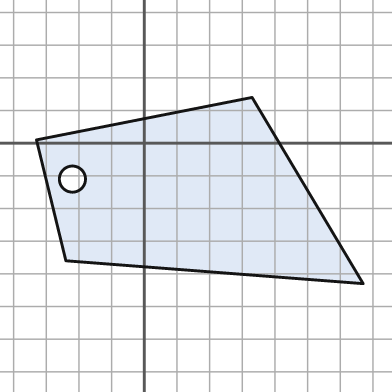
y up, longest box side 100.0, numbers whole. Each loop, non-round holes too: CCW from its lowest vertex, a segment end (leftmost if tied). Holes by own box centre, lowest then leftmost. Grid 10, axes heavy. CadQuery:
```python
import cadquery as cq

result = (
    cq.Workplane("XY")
    .moveTo(67.0, -43.0)
    .lineTo(33.0, 14.0)
    .lineTo(-33.0, 1.0)
    .lineTo(-24.0, -36.0)
    .close()
    .moveTo(-22.0, -11.0)
    .circle(4.0)
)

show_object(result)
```